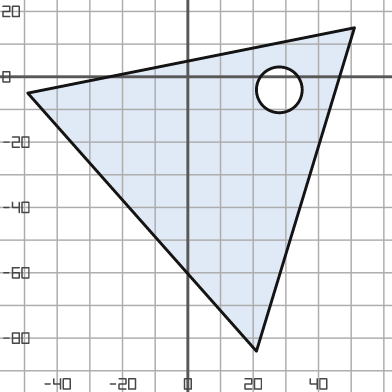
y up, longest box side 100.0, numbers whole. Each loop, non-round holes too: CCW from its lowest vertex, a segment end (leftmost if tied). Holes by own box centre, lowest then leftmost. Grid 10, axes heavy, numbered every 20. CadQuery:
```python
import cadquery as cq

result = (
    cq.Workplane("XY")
    .moveTo(21.0, -84.0)
    .lineTo(51.0, 15.0)
    .lineTo(-49.0, -5.0)
    .close()
    .moveTo(28.0, -4.0)
    .circle(7.0)
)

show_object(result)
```